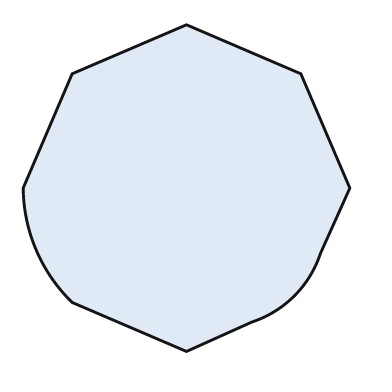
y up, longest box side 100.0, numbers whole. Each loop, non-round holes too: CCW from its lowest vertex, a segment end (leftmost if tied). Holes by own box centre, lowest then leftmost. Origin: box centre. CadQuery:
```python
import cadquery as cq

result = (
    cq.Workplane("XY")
    .moveTo(0.0, -50.0)
    .lineTo(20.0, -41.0)
    .threePointArc((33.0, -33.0), (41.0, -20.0))
    .lineTo(50.0, 0.0)
    .lineTo(35.0, 35.0)
    .lineTo(0.0, 50.0)
    .lineTo(-35.0, 35.0)
    .lineTo(-50.0, 0.0)
    .threePointArc((-46.0, -19.0), (-35.0, -35.0))
    .close()
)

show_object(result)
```